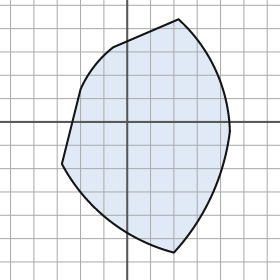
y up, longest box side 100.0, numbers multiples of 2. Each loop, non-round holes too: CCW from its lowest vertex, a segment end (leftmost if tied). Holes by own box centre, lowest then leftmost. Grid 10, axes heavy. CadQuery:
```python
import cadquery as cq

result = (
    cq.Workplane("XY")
    .moveTo(20.0, -56.0)
    .threePointArc((36.0, -32.0), (44.0, -4.0))
    .threePointArc((38.0, 22.0), (22.0, 44.0))
    .lineTo(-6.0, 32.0)
    .threePointArc((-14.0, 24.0), (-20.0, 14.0))
    .lineTo(-28.0, -18.0)
    .threePointArc((-8.0, -42.0), (20.0, -56.0))
    .close()
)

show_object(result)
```